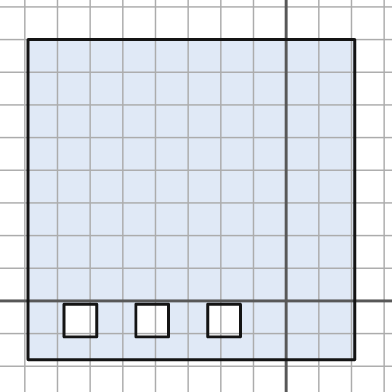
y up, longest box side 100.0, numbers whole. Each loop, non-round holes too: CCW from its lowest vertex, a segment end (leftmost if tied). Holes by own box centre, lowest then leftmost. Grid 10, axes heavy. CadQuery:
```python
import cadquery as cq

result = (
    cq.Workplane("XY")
    .moveTo(-79.0, -18.0)
    .lineTo(21.0, -18.0)
    .lineTo(21.0, 80.0)
    .lineTo(-79.0, 80.0)
    .close()
    .moveTo(-68.0, -11.0)
    .lineTo(-58.0, -11.0)
    .lineTo(-58.0, -1.0)
    .lineTo(-68.0, -1.0)
    .close()
    .moveTo(-46.0, -11.0)
    .lineTo(-36.0, -11.0)
    .lineTo(-36.0, -1.0)
    .lineTo(-46.0, -1.0)
    .close()
    .moveTo(-24.0, -11.0)
    .lineTo(-14.0, -11.0)
    .lineTo(-14.0, -1.0)
    .lineTo(-24.0, -1.0)
    .close()
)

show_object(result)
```